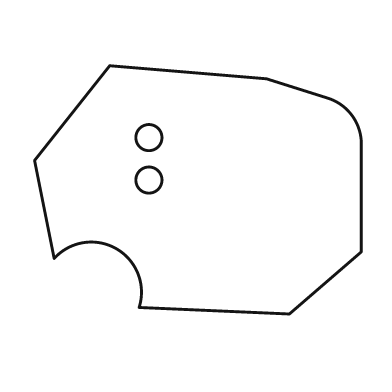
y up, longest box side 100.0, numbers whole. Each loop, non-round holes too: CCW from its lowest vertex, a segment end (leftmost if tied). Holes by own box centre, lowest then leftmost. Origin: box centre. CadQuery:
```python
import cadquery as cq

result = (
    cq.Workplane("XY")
    .moveTo(28.0, -38.0)
    .lineTo(50.0, -19.0)
    .lineTo(50.0, 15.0)
    .threePointArc((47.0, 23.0), (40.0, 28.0))
    .lineTo(21.0, 34.0)
    .lineTo(-27.0, 38.0)
    .lineTo(-50.0, 9.0)
    .lineTo(-44.0, -21.0)
    .threePointArc((-25.0, -18.0), (-18.0, -36.0))
    .close()
    .moveTo(-15.0, 3.0)
    .circle(4.0)
    .moveTo(-15.0, 16.0)
    .circle(4.0)
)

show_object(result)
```